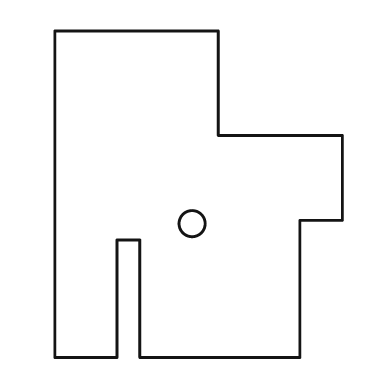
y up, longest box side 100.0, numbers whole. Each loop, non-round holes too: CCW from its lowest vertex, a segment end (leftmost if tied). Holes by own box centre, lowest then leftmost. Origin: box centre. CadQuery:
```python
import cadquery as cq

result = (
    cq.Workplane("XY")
    .moveTo(-44.0, -50.0)
    .lineTo(-25.0, -50.0)
    .lineTo(-25.0, -14.0)
    .lineTo(-18.0, -14.0)
    .lineTo(-18.0, -50.0)
    .lineTo(31.0, -50.0)
    .lineTo(31.0, -8.0)
    .lineTo(44.0, -8.0)
    .lineTo(44.0, 18.0)
    .lineTo(6.0, 18.0)
    .lineTo(6.0, 50.0)
    .lineTo(-44.0, 50.0)
    .close()
    .moveTo(-2.0, -9.0)
    .circle(4.0)
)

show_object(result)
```